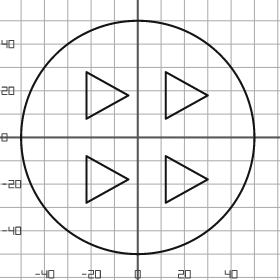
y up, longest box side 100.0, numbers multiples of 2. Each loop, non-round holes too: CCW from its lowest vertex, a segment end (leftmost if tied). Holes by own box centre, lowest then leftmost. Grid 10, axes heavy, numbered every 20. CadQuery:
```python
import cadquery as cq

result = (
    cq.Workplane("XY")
    .moveTo(0.0, 0.0)
    .circle(50.0)
    .moveTo(-22.0, -28.0)
    .lineTo(-4.0, -18.0)
    .lineTo(-22.0, -8.0)
    .close()
    .moveTo(12.0, -28.0)
    .lineTo(30.0, -18.0)
    .lineTo(12.0, -8.0)
    .close()
    .moveTo(-22.0, 8.0)
    .lineTo(-4.0, 18.0)
    .lineTo(-22.0, 28.0)
    .close()
    .moveTo(12.0, 8.0)
    .lineTo(30.0, 18.0)
    .lineTo(12.0, 28.0)
    .close()
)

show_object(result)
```